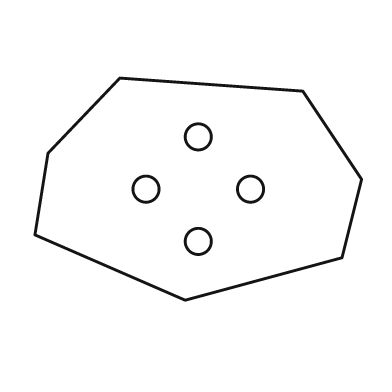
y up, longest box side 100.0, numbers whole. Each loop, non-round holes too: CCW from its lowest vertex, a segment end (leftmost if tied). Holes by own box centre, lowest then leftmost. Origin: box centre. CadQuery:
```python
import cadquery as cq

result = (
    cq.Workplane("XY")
    .moveTo(-4.0, -34.0)
    .lineTo(44.0, -21.0)
    .lineTo(50.0, 3.0)
    .lineTo(32.0, 30.0)
    .lineTo(-24.0, 34.0)
    .lineTo(-46.0, 11.0)
    .lineTo(-50.0, -14.0)
    .close()
    .moveTo(0.0, -16.0)
    .circle(4.0)
    .moveTo(-16.0, 0.0)
    .circle(4.0)
    .moveTo(16.0, 0.0)
    .circle(4.0)
    .moveTo(0.0, 16.0)
    .circle(4.0)
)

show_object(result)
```